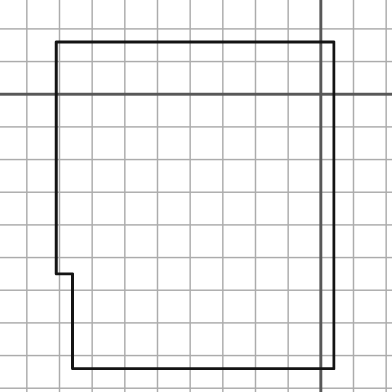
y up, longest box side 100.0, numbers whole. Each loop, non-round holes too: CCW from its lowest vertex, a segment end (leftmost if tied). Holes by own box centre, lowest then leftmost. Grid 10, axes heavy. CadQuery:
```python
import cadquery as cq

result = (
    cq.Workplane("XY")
    .moveTo(-76.0, -84.0)
    .lineTo(4.0, -84.0)
    .lineTo(4.0, 16.0)
    .lineTo(-81.0, 16.0)
    .lineTo(-81.0, -55.0)
    .lineTo(-76.0, -55.0)
    .close()
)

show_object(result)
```